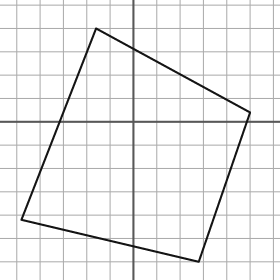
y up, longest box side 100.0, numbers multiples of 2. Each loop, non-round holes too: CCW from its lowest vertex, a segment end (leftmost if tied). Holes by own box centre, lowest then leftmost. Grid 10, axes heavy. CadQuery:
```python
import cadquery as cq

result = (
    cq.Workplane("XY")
    .moveTo(28.0, -60.0)
    .lineTo(50.0, 4.0)
    .lineTo(-16.0, 40.0)
    .lineTo(-48.0, -42.0)
    .close()
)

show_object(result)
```